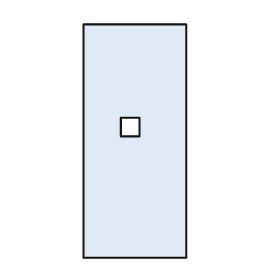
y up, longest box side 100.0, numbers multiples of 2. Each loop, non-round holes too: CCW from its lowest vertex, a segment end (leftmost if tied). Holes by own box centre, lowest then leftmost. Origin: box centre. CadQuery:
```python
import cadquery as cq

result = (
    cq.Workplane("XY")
    .moveTo(-22.0, -50.0)
    .lineTo(22.0, -50.0)
    .lineTo(22.0, 50.0)
    .lineTo(-22.0, 50.0)
    .close()
    .moveTo(-6.0, 2.0)
    .lineTo(2.0, 2.0)
    .lineTo(2.0, 10.0)
    .lineTo(-6.0, 10.0)
    .close()
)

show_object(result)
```